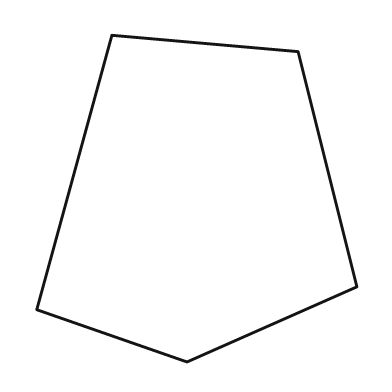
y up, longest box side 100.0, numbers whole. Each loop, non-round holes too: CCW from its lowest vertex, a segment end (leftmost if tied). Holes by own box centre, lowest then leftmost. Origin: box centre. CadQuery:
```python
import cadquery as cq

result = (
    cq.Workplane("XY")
    .moveTo(-3.0, -50.0)
    .lineTo(49.0, -27.0)
    .lineTo(31.0, 45.0)
    .lineTo(-26.0, 50.0)
    .lineTo(-49.0, -34.0)
    .close()
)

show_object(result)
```